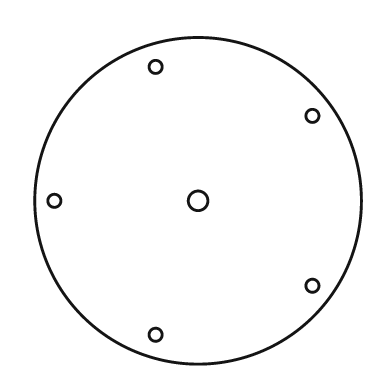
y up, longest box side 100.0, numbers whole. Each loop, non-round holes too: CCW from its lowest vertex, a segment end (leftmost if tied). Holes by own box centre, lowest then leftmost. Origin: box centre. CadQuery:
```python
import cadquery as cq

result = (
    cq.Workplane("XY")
    .moveTo(0.0, 0.0)
    .circle(50.0)
    .moveTo(-13.0, -41.0)
    .circle(2.0)
    .moveTo(35.0, -26.0)
    .circle(2.0)
    .moveTo(-44.0, 0.0)
    .circle(2.0)
    .moveTo(0.0, 0.0)
    .circle(3.0)
    .moveTo(35.0, 26.0)
    .circle(2.0)
    .moveTo(-13.0, 41.0)
    .circle(2.0)
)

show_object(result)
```